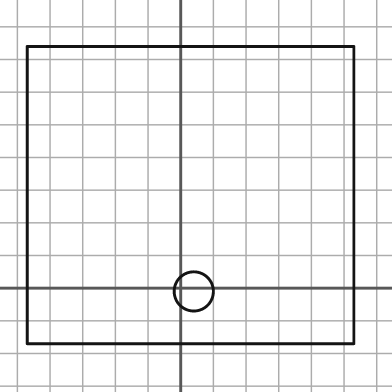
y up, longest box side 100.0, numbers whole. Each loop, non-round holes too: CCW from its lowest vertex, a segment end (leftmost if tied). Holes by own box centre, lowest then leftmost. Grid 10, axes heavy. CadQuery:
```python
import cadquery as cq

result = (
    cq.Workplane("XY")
    .moveTo(-47.0, -17.0)
    .lineTo(53.0, -17.0)
    .lineTo(53.0, 74.0)
    .lineTo(-47.0, 74.0)
    .close()
    .moveTo(4.0, -1.0)
    .circle(6.0)
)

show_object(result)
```